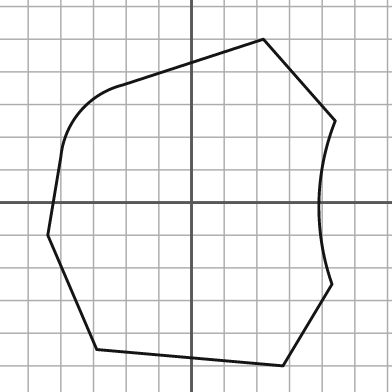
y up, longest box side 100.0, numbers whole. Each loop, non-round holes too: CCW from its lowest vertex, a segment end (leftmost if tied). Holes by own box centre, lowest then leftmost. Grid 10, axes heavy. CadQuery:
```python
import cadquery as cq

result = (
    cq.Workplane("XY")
    .moveTo(28.0, -50.0)
    .lineTo(43.0, -25.0)
    .threePointArc((39.0, 0.0), (44.0, 25.0))
    .lineTo(22.0, 50.0)
    .lineTo(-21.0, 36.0)
    .threePointArc((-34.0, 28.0), (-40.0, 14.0))
    .lineTo(-44.0, -10.0)
    .lineTo(-29.0, -45.0)
    .close()
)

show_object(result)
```